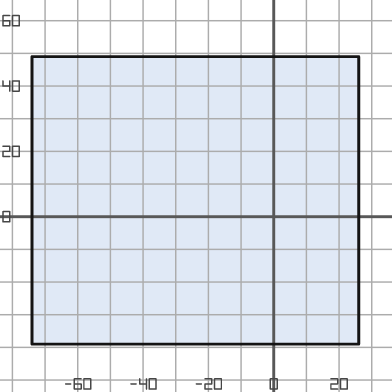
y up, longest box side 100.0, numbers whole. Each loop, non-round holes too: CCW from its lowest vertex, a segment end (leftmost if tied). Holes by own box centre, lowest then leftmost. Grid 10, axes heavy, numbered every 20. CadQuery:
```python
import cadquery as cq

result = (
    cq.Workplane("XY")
    .moveTo(-74.0, -39.0)
    .lineTo(26.0, -39.0)
    .lineTo(26.0, 49.0)
    .lineTo(-74.0, 49.0)
    .close()
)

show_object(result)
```